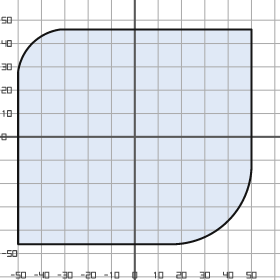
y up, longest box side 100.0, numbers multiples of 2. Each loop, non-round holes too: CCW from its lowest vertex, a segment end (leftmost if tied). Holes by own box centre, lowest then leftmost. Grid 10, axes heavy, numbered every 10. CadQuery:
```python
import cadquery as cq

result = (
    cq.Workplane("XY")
    .moveTo(-50.0, -46.0)
    .lineTo(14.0, -46.0)
    .threePointArc((40.0, -36.0), (50.0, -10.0))
    .lineTo(50.0, 46.0)
    .lineTo(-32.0, 46.0)
    .threePointArc((-44.0, 40.0), (-50.0, 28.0))
    .close()
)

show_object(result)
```